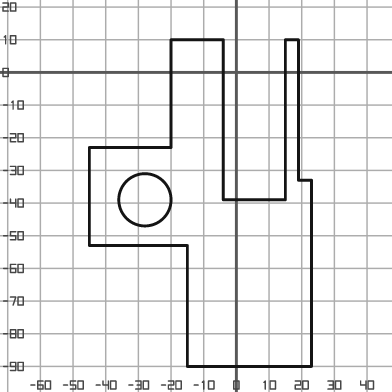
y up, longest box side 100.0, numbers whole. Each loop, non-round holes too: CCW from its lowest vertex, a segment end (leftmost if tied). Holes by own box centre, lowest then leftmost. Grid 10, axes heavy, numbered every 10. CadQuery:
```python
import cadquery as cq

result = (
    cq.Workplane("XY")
    .moveTo(-15.0, -90.0)
    .lineTo(23.0, -90.0)
    .lineTo(23.0, -33.0)
    .lineTo(19.0, -33.0)
    .lineTo(19.0, 10.0)
    .lineTo(15.0, 10.0)
    .lineTo(15.0, -39.0)
    .lineTo(-4.0, -39.0)
    .lineTo(-4.0, 10.0)
    .lineTo(-20.0, 10.0)
    .lineTo(-20.0, -23.0)
    .lineTo(-45.0, -23.0)
    .lineTo(-45.0, -53.0)
    .lineTo(-15.0, -53.0)
    .close()
    .moveTo(-28.0, -39.0)
    .circle(8.0)
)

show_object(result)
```